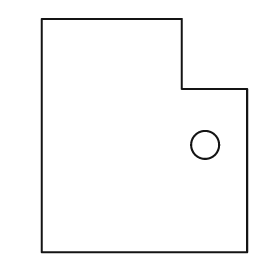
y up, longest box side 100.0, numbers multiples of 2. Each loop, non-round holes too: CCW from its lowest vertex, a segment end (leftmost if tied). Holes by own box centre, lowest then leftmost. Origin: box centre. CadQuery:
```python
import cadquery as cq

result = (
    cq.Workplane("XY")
    .moveTo(-44.0, -50.0)
    .lineTo(44.0, -50.0)
    .lineTo(44.0, 20.0)
    .lineTo(16.0, 20.0)
    .lineTo(16.0, 50.0)
    .lineTo(-44.0, 50.0)
    .close()
    .moveTo(26.0, -4.0)
    .circle(6.0)
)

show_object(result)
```